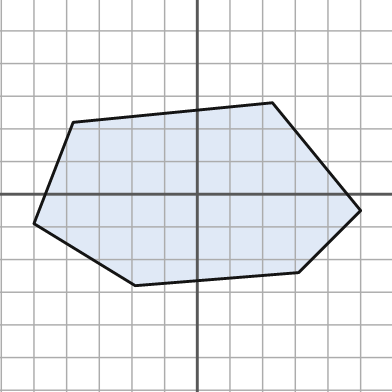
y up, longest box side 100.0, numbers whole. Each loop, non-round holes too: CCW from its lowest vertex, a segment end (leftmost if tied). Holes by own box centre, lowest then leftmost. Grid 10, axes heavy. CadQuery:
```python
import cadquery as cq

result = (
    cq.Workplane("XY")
    .moveTo(-19.0, -28.0)
    .lineTo(31.0, -24.0)
    .lineTo(50.0, -5.0)
    .lineTo(23.0, 28.0)
    .lineTo(-38.0, 22.0)
    .lineTo(-50.0, -9.0)
    .close()
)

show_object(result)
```